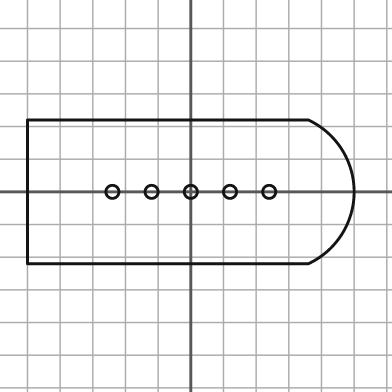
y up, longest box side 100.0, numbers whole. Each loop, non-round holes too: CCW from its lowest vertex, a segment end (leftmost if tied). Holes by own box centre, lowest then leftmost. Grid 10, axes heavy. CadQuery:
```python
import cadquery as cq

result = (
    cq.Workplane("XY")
    .moveTo(-50.0, -22.0)
    .lineTo(36.0, -22.0)
    .threePointArc((50.0, 0.0), (36.0, 22.0))
    .lineTo(-50.0, 22.0)
    .close()
    .moveTo(-24.0, 0.0)
    .circle(2.0)
    .moveTo(-12.0, 0.0)
    .circle(2.0)
    .moveTo(0.0, 0.0)
    .circle(2.0)
    .moveTo(12.0, 0.0)
    .circle(2.0)
    .moveTo(24.0, 0.0)
    .circle(2.0)
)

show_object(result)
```